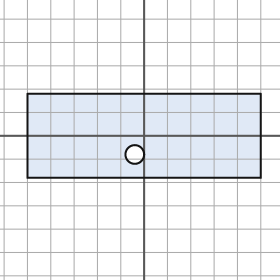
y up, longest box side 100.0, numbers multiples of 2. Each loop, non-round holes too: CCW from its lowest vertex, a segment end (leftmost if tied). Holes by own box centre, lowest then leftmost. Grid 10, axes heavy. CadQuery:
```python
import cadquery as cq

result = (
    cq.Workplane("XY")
    .moveTo(-50.0, -18.0)
    .lineTo(50.0, -18.0)
    .lineTo(50.0, 18.0)
    .lineTo(-50.0, 18.0)
    .close()
    .moveTo(-4.0, -8.0)
    .circle(4.0)
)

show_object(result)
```